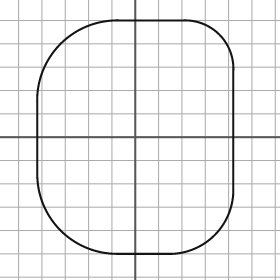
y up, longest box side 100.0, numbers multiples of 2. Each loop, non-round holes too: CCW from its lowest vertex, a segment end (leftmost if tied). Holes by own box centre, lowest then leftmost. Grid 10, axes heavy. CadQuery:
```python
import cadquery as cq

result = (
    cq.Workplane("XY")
    .moveTo(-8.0, -50.0)
    .lineTo(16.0, -50.0)
    .threePointArc((34.0, -42.0), (42.0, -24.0))
    .lineTo(42.0, 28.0)
    .threePointArc((36.0, 44.0), (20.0, 50.0))
    .lineTo(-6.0, 50.0)
    .threePointArc((-32.0, 40.0), (-42.0, 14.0))
    .lineTo(-42.0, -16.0)
    .threePointArc((-32.0, -40.0), (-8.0, -50.0))
    .close()
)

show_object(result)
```